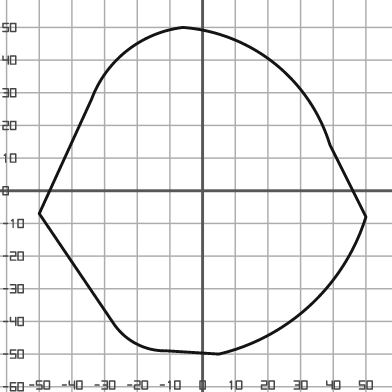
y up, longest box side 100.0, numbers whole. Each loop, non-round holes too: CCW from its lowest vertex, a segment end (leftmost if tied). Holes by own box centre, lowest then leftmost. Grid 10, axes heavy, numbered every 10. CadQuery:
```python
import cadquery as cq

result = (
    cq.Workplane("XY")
    .moveTo(5.0, -50.0)
    .threePointArc((33.0, -35.0), (50.0, -8.0))
    .lineTo(39.0, 14.0)
    .threePointArc((22.0, 39.0), (-6.0, 50.0))
    .threePointArc((-23.0, 43.0), (-34.0, 28.0))
    .lineTo(-50.0, -7.0)
    .lineTo(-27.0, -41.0)
    .threePointArc((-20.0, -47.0), (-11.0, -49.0))
    .close()
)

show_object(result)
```